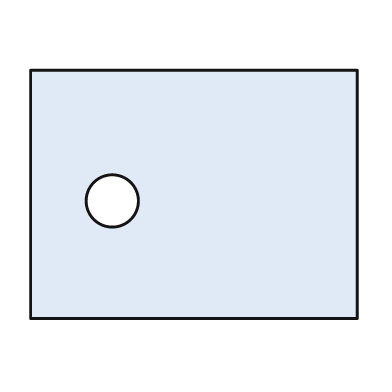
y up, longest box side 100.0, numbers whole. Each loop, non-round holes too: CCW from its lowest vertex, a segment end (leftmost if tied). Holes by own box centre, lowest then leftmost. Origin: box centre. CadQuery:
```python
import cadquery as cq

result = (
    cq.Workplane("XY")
    .moveTo(-50.0, -38.0)
    .lineTo(50.0, -38.0)
    .lineTo(50.0, 38.0)
    .lineTo(-50.0, 38.0)
    .close()
    .moveTo(-25.0, -2.0)
    .circle(8.0)
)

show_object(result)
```